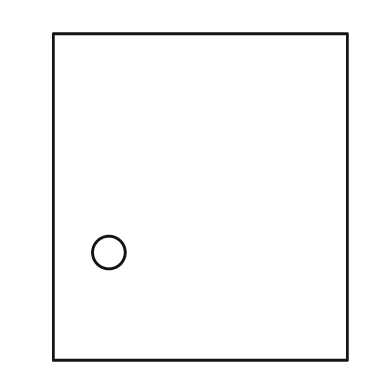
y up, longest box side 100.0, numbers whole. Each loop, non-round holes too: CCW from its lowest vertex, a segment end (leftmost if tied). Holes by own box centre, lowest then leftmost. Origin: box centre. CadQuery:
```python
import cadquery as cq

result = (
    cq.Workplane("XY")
    .moveTo(-45.0, -50.0)
    .lineTo(45.0, -50.0)
    .lineTo(45.0, 50.0)
    .lineTo(-45.0, 50.0)
    .close()
    .moveTo(-28.0, -17.0)
    .circle(5.0)
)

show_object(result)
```